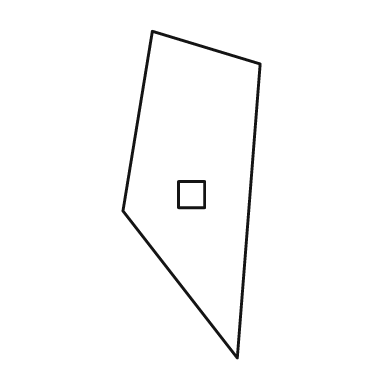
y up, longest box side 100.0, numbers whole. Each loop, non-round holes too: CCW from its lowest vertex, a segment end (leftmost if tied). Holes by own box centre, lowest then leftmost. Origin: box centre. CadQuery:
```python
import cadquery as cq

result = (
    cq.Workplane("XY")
    .moveTo(14.0, -50.0)
    .lineTo(21.0, 40.0)
    .lineTo(-12.0, 50.0)
    .lineTo(-21.0, -5.0)
    .close()
    .moveTo(-4.0, -4.0)
    .lineTo(4.0, -4.0)
    .lineTo(4.0, 4.0)
    .lineTo(-4.0, 4.0)
    .close()
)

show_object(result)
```